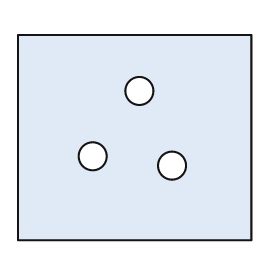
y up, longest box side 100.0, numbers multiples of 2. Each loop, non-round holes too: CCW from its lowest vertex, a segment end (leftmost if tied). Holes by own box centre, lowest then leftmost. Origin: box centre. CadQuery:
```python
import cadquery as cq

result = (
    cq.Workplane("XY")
    .moveTo(-50.0, -44.0)
    .lineTo(50.0, -44.0)
    .lineTo(50.0, 44.0)
    .lineTo(-50.0, 44.0)
    .close()
    .moveTo(16.0, -12.0)
    .circle(6.0)
    .moveTo(-18.0, -8.0)
    .circle(6.0)
    .moveTo(2.0, 20.0)
    .circle(6.0)
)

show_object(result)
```